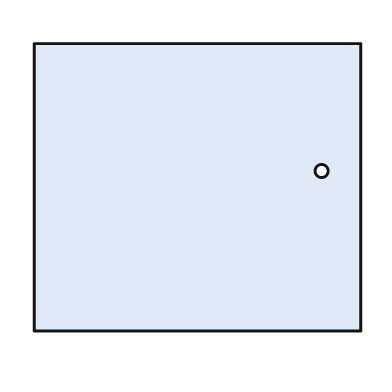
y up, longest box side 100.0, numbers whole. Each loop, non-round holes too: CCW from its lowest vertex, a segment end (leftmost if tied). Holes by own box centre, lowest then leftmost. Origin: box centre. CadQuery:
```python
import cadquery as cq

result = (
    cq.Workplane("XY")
    .moveTo(-50.0, -44.0)
    .lineTo(50.0, -44.0)
    .lineTo(50.0, 44.0)
    .lineTo(-50.0, 44.0)
    .close()
    .moveTo(38.0, 5.0)
    .circle(2.0)
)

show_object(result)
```